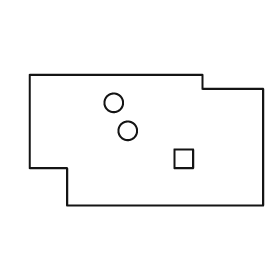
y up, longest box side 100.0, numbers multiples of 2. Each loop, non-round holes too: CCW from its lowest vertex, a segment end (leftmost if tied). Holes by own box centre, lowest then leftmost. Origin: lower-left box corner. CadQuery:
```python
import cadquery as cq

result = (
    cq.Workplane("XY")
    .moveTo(16.0, 0.0)
    .lineTo(100.0, 0.0)
    .lineTo(100.0, 50.0)
    .lineTo(74.0, 50.0)
    .lineTo(74.0, 56.0)
    .lineTo(0.0, 56.0)
    .lineTo(0.0, 16.0)
    .lineTo(16.0, 16.0)
    .close()
    .moveTo(62.0, 16.0)
    .lineTo(70.0, 16.0)
    .lineTo(70.0, 24.0)
    .lineTo(62.0, 24.0)
    .close()
    .moveTo(42.0, 32.0)
    .circle(4.0)
    .moveTo(36.0, 44.0)
    .circle(4.0)
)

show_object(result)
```